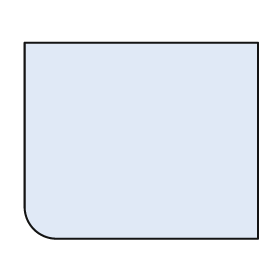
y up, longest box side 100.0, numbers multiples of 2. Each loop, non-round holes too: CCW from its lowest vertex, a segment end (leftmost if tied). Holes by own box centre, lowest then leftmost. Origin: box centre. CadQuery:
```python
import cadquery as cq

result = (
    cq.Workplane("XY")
    .moveTo(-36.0, -42.0)
    .lineTo(50.0, -42.0)
    .lineTo(50.0, 42.0)
    .lineTo(-50.0, 42.0)
    .lineTo(-50.0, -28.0)
    .threePointArc((-46.0, -38.0), (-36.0, -42.0))
    .close()
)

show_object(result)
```